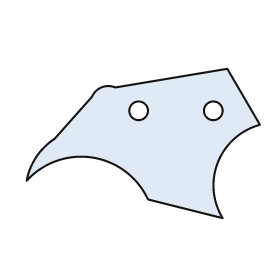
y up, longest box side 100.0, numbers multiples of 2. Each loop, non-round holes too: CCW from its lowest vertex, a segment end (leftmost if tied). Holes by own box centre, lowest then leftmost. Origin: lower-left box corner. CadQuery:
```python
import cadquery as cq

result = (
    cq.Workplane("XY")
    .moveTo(84.0, 0.0)
    .threePointArc((82.0, 24.0), (100.0, 40.0))
    .lineTo(86.0, 64.0)
    .lineTo(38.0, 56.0)
    .threePointArc((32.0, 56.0), (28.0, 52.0))
    .lineTo(12.0, 34.0)
    .threePointArc((4.0, 26.0), (0.0, 16.0))
    .threePointArc((28.0, 26.0), (52.0, 8.0))
    .close()
    .moveTo(48.0, 46.0)
    .circle(4.0)
    .moveTo(80.0, 46.0)
    .circle(4.0)
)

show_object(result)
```